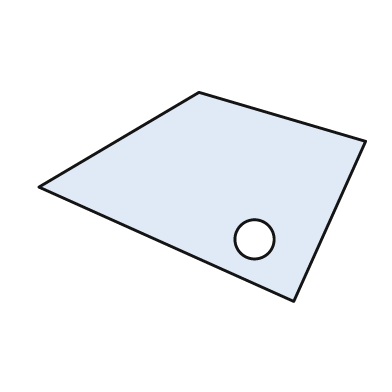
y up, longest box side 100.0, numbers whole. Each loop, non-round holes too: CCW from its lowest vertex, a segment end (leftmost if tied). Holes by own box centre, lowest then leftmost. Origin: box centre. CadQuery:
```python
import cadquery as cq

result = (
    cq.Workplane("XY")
    .moveTo(28.0, -32.0)
    .lineTo(50.0, 17.0)
    .lineTo(-1.0, 32.0)
    .lineTo(-50.0, 3.0)
    .close()
    .moveTo(16.0, -13.0)
    .circle(6.0)
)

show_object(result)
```